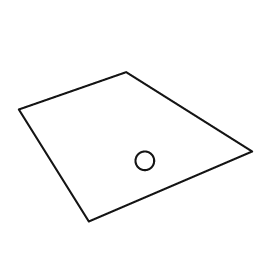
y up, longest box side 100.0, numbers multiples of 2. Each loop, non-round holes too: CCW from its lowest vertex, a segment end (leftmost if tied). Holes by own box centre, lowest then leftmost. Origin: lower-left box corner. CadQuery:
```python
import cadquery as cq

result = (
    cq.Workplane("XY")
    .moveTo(30.0, 0.0)
    .lineTo(100.0, 30.0)
    .lineTo(46.0, 64.0)
    .lineTo(0.0, 48.0)
    .close()
    .moveTo(54.0, 26.0)
    .circle(4.0)
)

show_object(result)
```